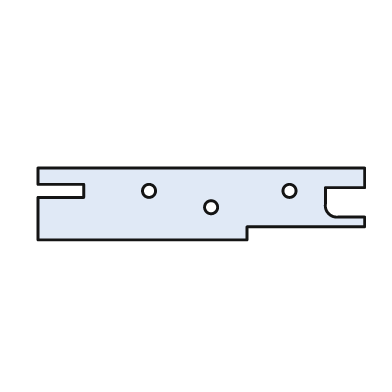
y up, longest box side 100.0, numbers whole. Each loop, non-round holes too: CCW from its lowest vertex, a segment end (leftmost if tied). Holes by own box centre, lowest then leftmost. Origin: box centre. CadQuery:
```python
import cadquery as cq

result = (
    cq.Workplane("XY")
    .moveTo(-50.0, -11.0)
    .lineTo(14.0, -11.0)
    .lineTo(14.0, -7.0)
    .lineTo(50.0, -7.0)
    .lineTo(50.0, -4.0)
    .lineTo(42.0, -4.0)
    .threePointArc((39.0, -3.0), (38.0, 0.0))
    .lineTo(38.0, 5.0)
    .lineTo(50.0, 5.0)
    .lineTo(50.0, 11.0)
    .lineTo(-50.0, 11.0)
    .lineTo(-50.0, 6.0)
    .lineTo(-36.0, 6.0)
    .lineTo(-36.0, 2.0)
    .lineTo(-50.0, 2.0)
    .close()
    .moveTo(3.0, -1.0)
    .circle(2.0)
    .moveTo(-16.0, 4.0)
    .circle(2.0)
    .moveTo(27.0, 4.0)
    .circle(2.0)
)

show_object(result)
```